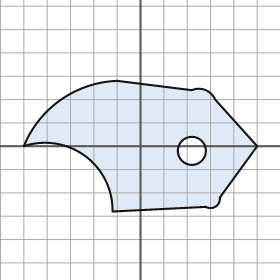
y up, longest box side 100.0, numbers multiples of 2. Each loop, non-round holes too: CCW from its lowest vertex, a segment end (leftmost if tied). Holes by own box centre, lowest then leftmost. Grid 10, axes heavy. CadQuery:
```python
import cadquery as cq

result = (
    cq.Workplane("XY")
    .moveTo(-12.0, -28.0)
    .lineTo(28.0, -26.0)
    .threePointArc((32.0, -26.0), (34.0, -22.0))
    .lineTo(50.0, 0.0)
    .lineTo(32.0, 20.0)
    .threePointArc((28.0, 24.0), (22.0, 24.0))
    .lineTo(-10.0, 28.0)
    .threePointArc((-34.0, 20.0), (-50.0, 0.0))
    .threePointArc((-24.0, -4.0), (-12.0, -28.0))
    .close()
    .moveTo(22.0, -2.0)
    .circle(6.0)
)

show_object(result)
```